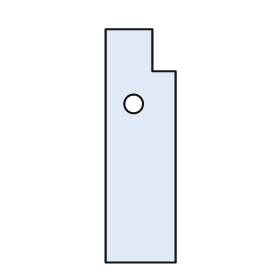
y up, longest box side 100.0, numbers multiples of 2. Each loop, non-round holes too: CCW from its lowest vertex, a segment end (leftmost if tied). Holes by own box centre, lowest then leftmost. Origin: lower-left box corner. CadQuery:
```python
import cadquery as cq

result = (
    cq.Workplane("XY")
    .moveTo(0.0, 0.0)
    .lineTo(30.0, 0.0)
    .lineTo(30.0, 82.0)
    .lineTo(20.0, 82.0)
    .lineTo(20.0, 100.0)
    .lineTo(0.0, 100.0)
    .close()
    .moveTo(12.0, 68.0)
    .circle(4.0)
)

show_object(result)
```